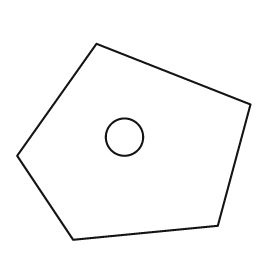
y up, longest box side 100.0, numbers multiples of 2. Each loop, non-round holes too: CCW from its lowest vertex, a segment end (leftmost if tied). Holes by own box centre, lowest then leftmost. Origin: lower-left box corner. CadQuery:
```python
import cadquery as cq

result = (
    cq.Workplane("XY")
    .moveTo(24.0, 0.0)
    .lineTo(86.0, 6.0)
    .lineTo(100.0, 58.0)
    .lineTo(34.0, 84.0)
    .lineTo(0.0, 36.0)
    .close()
    .moveTo(46.0, 44.0)
    .circle(8.0)
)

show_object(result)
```